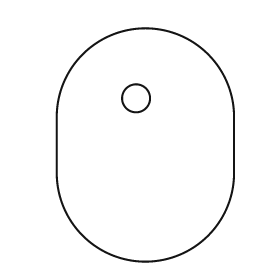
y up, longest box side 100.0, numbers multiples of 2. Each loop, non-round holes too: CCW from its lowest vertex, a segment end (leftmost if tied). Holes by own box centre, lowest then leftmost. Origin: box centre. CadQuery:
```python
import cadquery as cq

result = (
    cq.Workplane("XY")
    .moveTo(-38.0, -12.0)
    .threePointArc((0.0, -50.0), (38.0, -12.0))
    .lineTo(38.0, 12.0)
    .threePointArc((0.0, 50.0), (-38.0, 12.0))
    .close()
    .moveTo(-4.0, 20.0)
    .circle(6.0)
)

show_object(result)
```